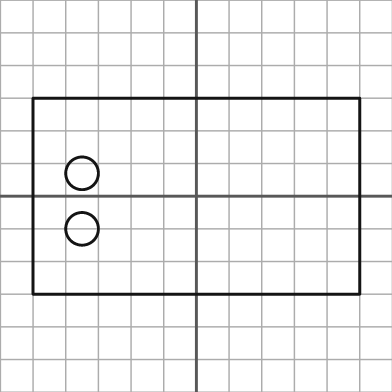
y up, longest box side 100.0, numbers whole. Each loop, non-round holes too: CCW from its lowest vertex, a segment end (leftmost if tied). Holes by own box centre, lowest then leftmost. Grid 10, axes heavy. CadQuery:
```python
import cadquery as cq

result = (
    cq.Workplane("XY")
    .moveTo(-50.0, -30.0)
    .lineTo(50.0, -30.0)
    .lineTo(50.0, 30.0)
    .lineTo(-50.0, 30.0)
    .close()
    .moveTo(-35.0, -10.0)
    .circle(5.0)
    .moveTo(-35.0, 7.0)
    .circle(5.0)
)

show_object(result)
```